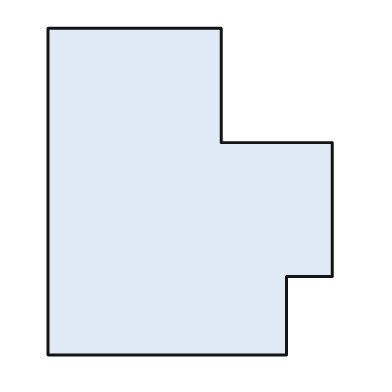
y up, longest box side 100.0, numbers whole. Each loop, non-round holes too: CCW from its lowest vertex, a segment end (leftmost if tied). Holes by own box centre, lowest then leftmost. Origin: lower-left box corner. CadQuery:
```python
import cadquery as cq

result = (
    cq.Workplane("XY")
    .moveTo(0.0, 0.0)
    .lineTo(73.0, 0.0)
    .lineTo(73.0, 24.0)
    .lineTo(87.0, 24.0)
    .lineTo(87.0, 65.0)
    .lineTo(53.0, 65.0)
    .lineTo(53.0, 100.0)
    .lineTo(0.0, 100.0)
    .close()
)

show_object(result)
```